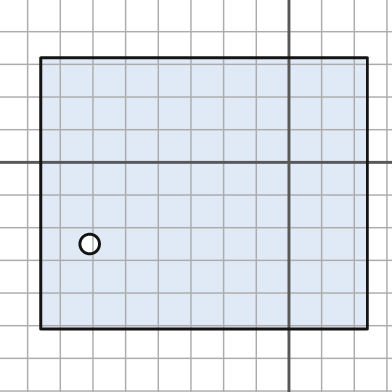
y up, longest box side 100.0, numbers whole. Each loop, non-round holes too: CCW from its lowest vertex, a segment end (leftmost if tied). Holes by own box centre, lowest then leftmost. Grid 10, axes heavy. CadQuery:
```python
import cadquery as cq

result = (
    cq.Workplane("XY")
    .moveTo(-76.0, -51.0)
    .lineTo(24.0, -51.0)
    .lineTo(24.0, 32.0)
    .lineTo(-76.0, 32.0)
    .close()
    .moveTo(-61.0, -25.0)
    .circle(3.0)
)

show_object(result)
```